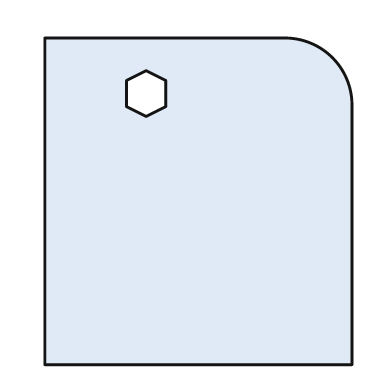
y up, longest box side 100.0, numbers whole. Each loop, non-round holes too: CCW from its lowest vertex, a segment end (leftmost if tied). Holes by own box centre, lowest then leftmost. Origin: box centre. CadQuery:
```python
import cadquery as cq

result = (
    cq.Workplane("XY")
    .moveTo(-47.0, -50.0)
    .lineTo(47.0, -50.0)
    .lineTo(47.0, 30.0)
    .threePointArc((41.0, 44.0), (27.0, 50.0))
    .lineTo(-47.0, 50.0)
    .close()
    .moveTo(-16.0, 26.0)
    .lineTo(-10.0, 29.0)
    .lineTo(-10.0, 37.0)
    .lineTo(-16.0, 40.0)
    .lineTo(-22.0, 37.0)
    .lineTo(-22.0, 29.0)
    .close()
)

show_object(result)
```